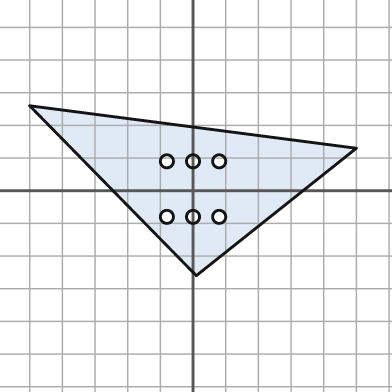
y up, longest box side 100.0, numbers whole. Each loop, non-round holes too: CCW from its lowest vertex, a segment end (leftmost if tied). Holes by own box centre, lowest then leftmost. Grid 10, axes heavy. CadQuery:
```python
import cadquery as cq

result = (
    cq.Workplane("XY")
    .moveTo(1.0, -26.0)
    .lineTo(50.0, 13.0)
    .lineTo(-50.0, 26.0)
    .close()
    .moveTo(-8.0, -8.0)
    .circle(2.0)
    .moveTo(0.0, -8.0)
    .circle(2.0)
    .moveTo(8.0, -8.0)
    .circle(2.0)
    .moveTo(-8.0, 9.0)
    .circle(2.0)
    .moveTo(0.0, 9.0)
    .circle(2.0)
    .moveTo(8.0, 9.0)
    .circle(2.0)
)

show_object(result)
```